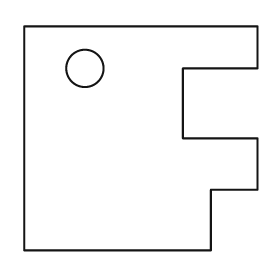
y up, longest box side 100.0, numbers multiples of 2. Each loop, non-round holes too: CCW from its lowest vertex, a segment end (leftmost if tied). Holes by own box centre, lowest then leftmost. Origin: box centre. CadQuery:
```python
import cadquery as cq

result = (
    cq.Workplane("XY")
    .moveTo(-50.0, -48.0)
    .lineTo(30.0, -48.0)
    .lineTo(30.0, -22.0)
    .lineTo(50.0, -22.0)
    .lineTo(50.0, 0.0)
    .lineTo(18.0, 0.0)
    .lineTo(18.0, 30.0)
    .lineTo(50.0, 30.0)
    .lineTo(50.0, 48.0)
    .lineTo(-50.0, 48.0)
    .close()
    .moveTo(-24.0, 30.0)
    .circle(8.0)
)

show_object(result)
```